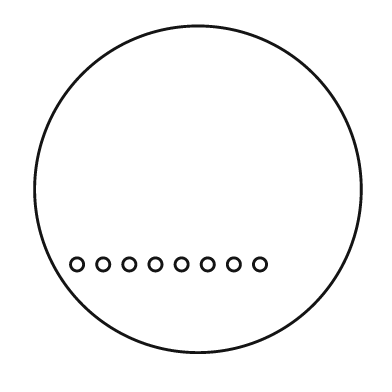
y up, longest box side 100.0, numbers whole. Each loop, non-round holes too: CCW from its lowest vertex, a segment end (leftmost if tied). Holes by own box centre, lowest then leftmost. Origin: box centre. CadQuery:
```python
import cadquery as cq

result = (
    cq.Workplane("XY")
    .moveTo(0.0, 0.0)
    .circle(50.0)
    .moveTo(-37.0, -23.0)
    .circle(2.0)
    .moveTo(-29.0, -23.0)
    .circle(2.0)
    .moveTo(-21.0, -23.0)
    .circle(2.0)
    .moveTo(-13.0, -23.0)
    .circle(2.0)
    .moveTo(-5.0, -23.0)
    .circle(2.0)
    .moveTo(3.0, -23.0)
    .circle(2.0)
    .moveTo(11.0, -23.0)
    .circle(2.0)
    .moveTo(19.0, -23.0)
    .circle(2.0)
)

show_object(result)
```